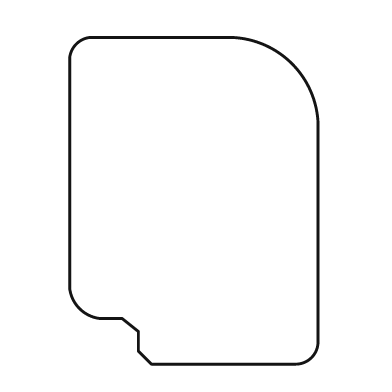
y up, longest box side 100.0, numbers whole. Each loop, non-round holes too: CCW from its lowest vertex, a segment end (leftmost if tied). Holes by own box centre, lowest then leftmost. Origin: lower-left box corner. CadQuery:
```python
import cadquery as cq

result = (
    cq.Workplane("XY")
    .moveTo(25.0, 0.0)
    .lineTo(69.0, 0.0)
    .threePointArc((74.0, 2.0), (76.0, 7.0))
    .lineTo(76.0, 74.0)
    .threePointArc((68.0, 92.0), (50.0, 100.0))
    .lineTo(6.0, 100.0)
    .threePointArc((2.0, 98.0), (0.0, 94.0))
    .lineTo(0.0, 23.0)
    .threePointArc((3.0, 17.0), (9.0, 14.0))
    .lineTo(16.0, 14.0)
    .lineTo(21.0, 10.0)
    .lineTo(21.0, 4.0)
    .close()
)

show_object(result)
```